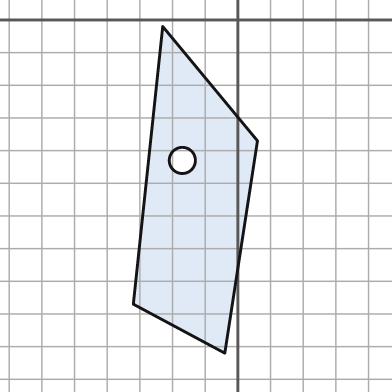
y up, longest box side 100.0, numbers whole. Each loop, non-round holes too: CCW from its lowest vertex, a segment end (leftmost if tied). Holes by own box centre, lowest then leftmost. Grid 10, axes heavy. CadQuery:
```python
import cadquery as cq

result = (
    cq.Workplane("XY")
    .moveTo(-4.0, -102.0)
    .lineTo(6.0, -37.0)
    .lineTo(-23.0, -2.0)
    .lineTo(-32.0, -87.0)
    .close()
    .moveTo(-17.0, -43.0)
    .circle(4.0)
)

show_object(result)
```